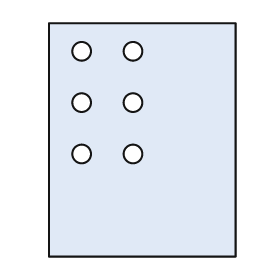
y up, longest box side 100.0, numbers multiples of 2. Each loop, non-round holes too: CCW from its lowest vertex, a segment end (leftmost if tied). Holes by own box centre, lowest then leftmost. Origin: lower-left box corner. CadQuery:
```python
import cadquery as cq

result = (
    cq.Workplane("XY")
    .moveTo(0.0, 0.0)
    .lineTo(80.0, 0.0)
    .lineTo(80.0, 100.0)
    .lineTo(0.0, 100.0)
    .close()
    .moveTo(14.0, 44.0)
    .circle(4.0)
    .moveTo(36.0, 44.0)
    .circle(4.0)
    .moveTo(14.0, 66.0)
    .circle(4.0)
    .moveTo(36.0, 66.0)
    .circle(4.0)
    .moveTo(14.0, 88.0)
    .circle(4.0)
    .moveTo(36.0, 88.0)
    .circle(4.0)
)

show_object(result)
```